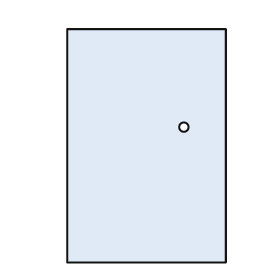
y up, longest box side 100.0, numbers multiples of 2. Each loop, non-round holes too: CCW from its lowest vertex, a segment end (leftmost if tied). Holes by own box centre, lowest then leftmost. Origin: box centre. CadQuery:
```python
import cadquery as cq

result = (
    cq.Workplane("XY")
    .moveTo(-34.0, -50.0)
    .lineTo(34.0, -50.0)
    .lineTo(34.0, 50.0)
    .lineTo(-34.0, 50.0)
    .close()
    .moveTo(16.0, 8.0)
    .circle(2.0)
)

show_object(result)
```